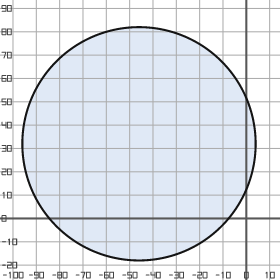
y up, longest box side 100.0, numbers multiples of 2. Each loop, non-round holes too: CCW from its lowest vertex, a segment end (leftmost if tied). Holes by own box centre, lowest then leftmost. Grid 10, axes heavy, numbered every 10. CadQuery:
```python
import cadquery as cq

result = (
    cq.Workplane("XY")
    .moveTo(-46.0, 32.0)
    .circle(50.0)
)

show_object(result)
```